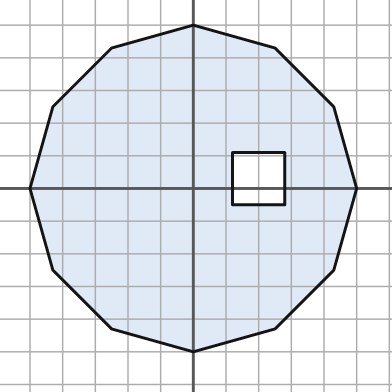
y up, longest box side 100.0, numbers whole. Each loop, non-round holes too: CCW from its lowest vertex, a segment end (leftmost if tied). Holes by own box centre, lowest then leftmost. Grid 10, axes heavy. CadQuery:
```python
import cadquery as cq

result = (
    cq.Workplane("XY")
    .moveTo(0.0, -50.0)
    .lineTo(25.0, -43.0)
    .lineTo(43.0, -25.0)
    .lineTo(50.0, 0.0)
    .lineTo(43.0, 25.0)
    .lineTo(25.0, 43.0)
    .lineTo(0.0, 50.0)
    .lineTo(-25.0, 43.0)
    .lineTo(-43.0, 25.0)
    .lineTo(-50.0, 0.0)
    .lineTo(-43.0, -25.0)
    .lineTo(-25.0, -43.0)
    .close()
    .moveTo(12.0, -5.0)
    .lineTo(28.0, -5.0)
    .lineTo(28.0, 11.0)
    .lineTo(12.0, 11.0)
    .close()
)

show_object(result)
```